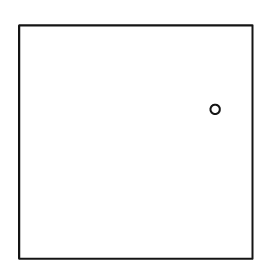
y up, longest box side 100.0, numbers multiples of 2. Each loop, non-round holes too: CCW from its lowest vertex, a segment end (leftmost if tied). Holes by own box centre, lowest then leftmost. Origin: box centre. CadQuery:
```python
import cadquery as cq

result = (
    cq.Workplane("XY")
    .moveTo(-50.0, -50.0)
    .lineTo(50.0, -50.0)
    .lineTo(50.0, 50.0)
    .lineTo(-50.0, 50.0)
    .close()
    .moveTo(34.0, 14.0)
    .circle(2.0)
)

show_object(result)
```